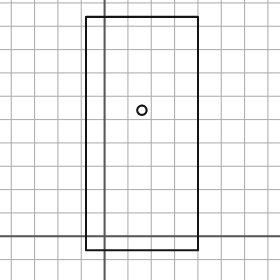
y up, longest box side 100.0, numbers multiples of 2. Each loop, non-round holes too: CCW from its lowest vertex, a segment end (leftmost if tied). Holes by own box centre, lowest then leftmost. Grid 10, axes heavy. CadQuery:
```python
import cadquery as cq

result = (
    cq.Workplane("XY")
    .moveTo(-8.0, -6.0)
    .lineTo(40.0, -6.0)
    .lineTo(40.0, 94.0)
    .lineTo(-8.0, 94.0)
    .close()
    .moveTo(16.0, 54.0)
    .circle(2.0)
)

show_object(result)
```